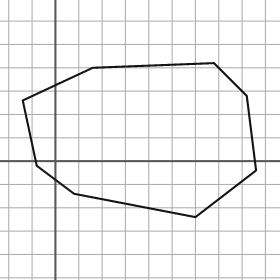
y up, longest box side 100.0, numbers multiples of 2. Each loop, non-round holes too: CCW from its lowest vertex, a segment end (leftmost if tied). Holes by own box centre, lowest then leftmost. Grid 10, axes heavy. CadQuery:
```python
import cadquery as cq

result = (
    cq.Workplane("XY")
    .moveTo(60.0, -24.0)
    .lineTo(86.0, -4.0)
    .lineTo(82.0, 28.0)
    .lineTo(68.0, 42.0)
    .lineTo(16.0, 40.0)
    .lineTo(-14.0, 26.0)
    .lineTo(-8.0, -2.0)
    .lineTo(8.0, -14.0)
    .close()
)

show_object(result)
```